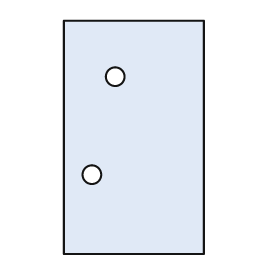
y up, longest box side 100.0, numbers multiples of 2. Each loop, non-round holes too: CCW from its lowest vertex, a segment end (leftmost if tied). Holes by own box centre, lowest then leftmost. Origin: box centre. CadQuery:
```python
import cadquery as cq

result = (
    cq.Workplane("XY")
    .moveTo(-30.0, -50.0)
    .lineTo(30.0, -50.0)
    .lineTo(30.0, 50.0)
    .lineTo(-30.0, 50.0)
    .close()
    .moveTo(-18.0, -16.0)
    .circle(4.0)
    .moveTo(-8.0, 26.0)
    .circle(4.0)
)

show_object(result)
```